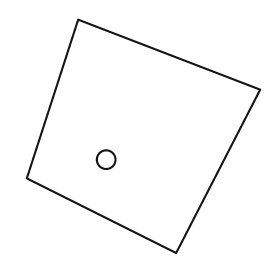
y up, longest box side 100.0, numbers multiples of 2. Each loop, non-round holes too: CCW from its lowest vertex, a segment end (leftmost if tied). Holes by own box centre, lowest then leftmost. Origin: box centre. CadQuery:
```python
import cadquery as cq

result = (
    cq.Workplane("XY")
    .moveTo(14.0, -50.0)
    .lineTo(50.0, 20.0)
    .lineTo(-28.0, 50.0)
    .lineTo(-50.0, -18.0)
    .close()
    .moveTo(-16.0, -10.0)
    .circle(4.0)
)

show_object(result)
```